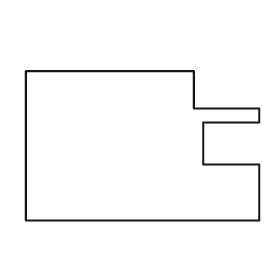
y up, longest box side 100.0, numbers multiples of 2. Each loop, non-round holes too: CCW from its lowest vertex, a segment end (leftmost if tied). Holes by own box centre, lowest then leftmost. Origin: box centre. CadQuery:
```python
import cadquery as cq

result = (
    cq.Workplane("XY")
    .moveTo(-50.0, -32.0)
    .lineTo(50.0, -32.0)
    .lineTo(50.0, -8.0)
    .lineTo(26.0, -8.0)
    .lineTo(26.0, 10.0)
    .lineTo(50.0, 10.0)
    .lineTo(50.0, 16.0)
    .lineTo(22.0, 16.0)
    .lineTo(22.0, 32.0)
    .lineTo(-50.0, 32.0)
    .close()
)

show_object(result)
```